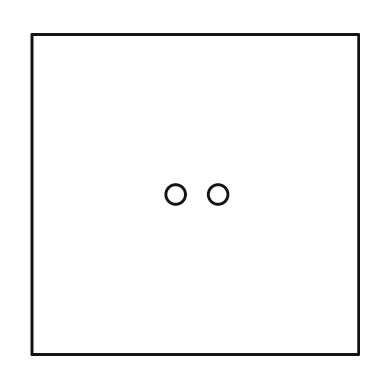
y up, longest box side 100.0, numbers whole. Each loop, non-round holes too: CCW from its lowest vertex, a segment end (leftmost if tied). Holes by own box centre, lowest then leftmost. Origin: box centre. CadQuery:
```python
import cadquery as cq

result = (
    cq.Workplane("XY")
    .moveTo(-50.0, -49.0)
    .lineTo(50.0, -49.0)
    .lineTo(50.0, 49.0)
    .lineTo(-50.0, 49.0)
    .close()
    .moveTo(-6.0, 0.0)
    .circle(3.0)
    .moveTo(7.0, 0.0)
    .circle(3.0)
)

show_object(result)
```